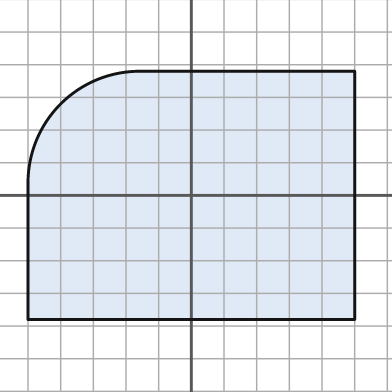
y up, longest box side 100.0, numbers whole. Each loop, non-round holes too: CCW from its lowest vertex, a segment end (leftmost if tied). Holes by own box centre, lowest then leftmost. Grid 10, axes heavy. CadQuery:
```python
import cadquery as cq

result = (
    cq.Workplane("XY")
    .moveTo(-50.0, -38.0)
    .lineTo(50.0, -38.0)
    .lineTo(50.0, 38.0)
    .lineTo(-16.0, 38.0)
    .threePointArc((-40.0, 28.0), (-50.0, 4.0))
    .close()
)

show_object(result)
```